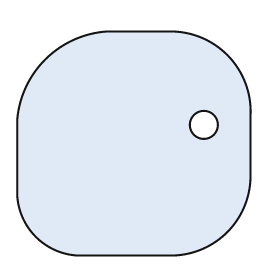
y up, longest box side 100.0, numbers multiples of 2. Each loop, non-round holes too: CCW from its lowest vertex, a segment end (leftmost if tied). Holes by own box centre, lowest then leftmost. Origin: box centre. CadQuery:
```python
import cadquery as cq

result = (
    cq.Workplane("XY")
    .moveTo(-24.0, -48.0)
    .lineTo(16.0, -48.0)
    .threePointArc((40.0, -38.0), (50.0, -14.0))
    .lineTo(50.0, 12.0)
    .threePointArc((40.0, 38.0), (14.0, 48.0))
    .lineTo(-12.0, 48.0)
    .threePointArc((-38.0, 36.0), (-50.0, 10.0))
    .lineTo(-50.0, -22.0)
    .threePointArc((-42.0, -40.0), (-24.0, -48.0))
    .close()
    .moveTo(30.0, 8.0)
    .circle(6.0)
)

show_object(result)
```